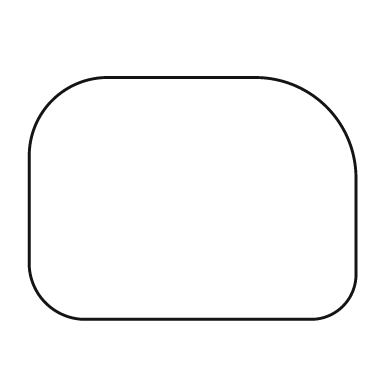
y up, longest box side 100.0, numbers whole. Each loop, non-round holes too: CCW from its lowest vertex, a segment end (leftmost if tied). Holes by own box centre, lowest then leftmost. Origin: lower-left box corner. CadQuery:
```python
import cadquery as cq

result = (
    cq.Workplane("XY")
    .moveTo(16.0, 0.0)
    .lineTo(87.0, 0.0)
    .threePointArc((96.0, 4.0), (100.0, 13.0))
    .lineTo(100.0, 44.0)
    .threePointArc((91.0, 65.0), (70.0, 74.0))
    .lineTo(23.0, 74.0)
    .threePointArc((7.0, 67.0), (0.0, 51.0))
    .lineTo(0.0, 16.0)
    .threePointArc((5.0, 5.0), (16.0, 0.0))
    .close()
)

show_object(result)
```